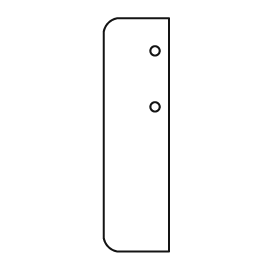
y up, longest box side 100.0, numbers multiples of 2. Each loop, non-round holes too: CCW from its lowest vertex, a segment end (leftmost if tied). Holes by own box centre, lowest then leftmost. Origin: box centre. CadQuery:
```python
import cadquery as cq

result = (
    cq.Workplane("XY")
    .moveTo(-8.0, -50.0)
    .lineTo(14.0, -50.0)
    .lineTo(14.0, 50.0)
    .lineTo(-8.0, 50.0)
    .threePointArc((-12.0, 48.0), (-14.0, 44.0))
    .lineTo(-14.0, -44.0)
    .threePointArc((-12.0, -48.0), (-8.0, -50.0))
    .close()
    .moveTo(8.0, 12.0)
    .circle(2.0)
    .moveTo(8.0, 36.0)
    .circle(2.0)
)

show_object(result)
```